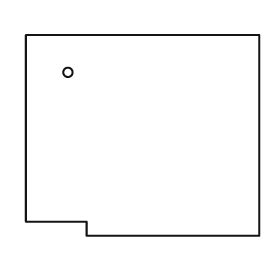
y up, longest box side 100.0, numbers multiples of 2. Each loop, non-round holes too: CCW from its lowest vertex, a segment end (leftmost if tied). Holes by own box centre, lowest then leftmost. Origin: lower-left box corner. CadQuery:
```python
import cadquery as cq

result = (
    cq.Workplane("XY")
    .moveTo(26.0, 0.0)
    .lineTo(100.0, 0.0)
    .lineTo(100.0, 86.0)
    .lineTo(0.0, 86.0)
    .lineTo(0.0, 6.0)
    .lineTo(26.0, 6.0)
    .close()
    .moveTo(18.0, 70.0)
    .circle(2.0)
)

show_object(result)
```